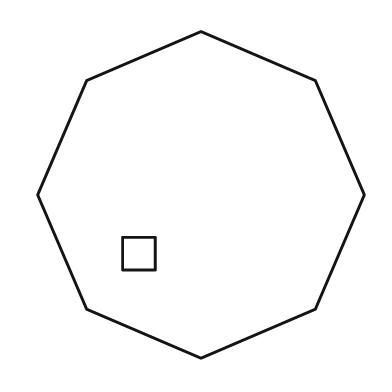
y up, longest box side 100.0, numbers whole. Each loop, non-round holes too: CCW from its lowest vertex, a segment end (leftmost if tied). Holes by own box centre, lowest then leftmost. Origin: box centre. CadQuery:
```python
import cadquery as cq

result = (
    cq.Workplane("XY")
    .moveTo(0.0, -50.0)
    .lineTo(35.0, -35.0)
    .lineTo(50.0, 0.0)
    .lineTo(35.0, 35.0)
    .lineTo(0.0, 50.0)
    .lineTo(-35.0, 35.0)
    .lineTo(-50.0, 0.0)
    .lineTo(-35.0, -35.0)
    .close()
    .moveTo(-24.0, -23.0)
    .lineTo(-14.0, -23.0)
    .lineTo(-14.0, -13.0)
    .lineTo(-24.0, -13.0)
    .close()
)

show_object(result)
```